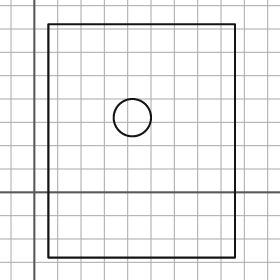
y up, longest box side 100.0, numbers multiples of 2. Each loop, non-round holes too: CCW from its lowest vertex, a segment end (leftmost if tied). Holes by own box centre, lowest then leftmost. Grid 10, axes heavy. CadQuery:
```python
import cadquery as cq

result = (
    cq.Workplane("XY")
    .moveTo(6.0, -28.0)
    .lineTo(86.0, -28.0)
    .lineTo(86.0, 72.0)
    .lineTo(6.0, 72.0)
    .close()
    .moveTo(42.0, 32.0)
    .circle(8.0)
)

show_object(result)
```